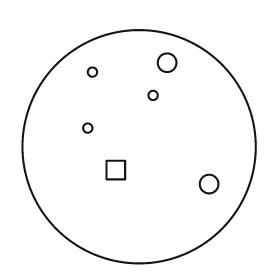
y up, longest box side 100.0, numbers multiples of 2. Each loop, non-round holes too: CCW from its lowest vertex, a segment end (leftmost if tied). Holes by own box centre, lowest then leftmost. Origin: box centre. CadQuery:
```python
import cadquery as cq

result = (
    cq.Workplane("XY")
    .moveTo(0.0, 0.0)
    .circle(50.0)
    .moveTo(30.0, -16.0)
    .circle(4.0)
    .moveTo(-14.0, -14.0)
    .lineTo(-6.0, -14.0)
    .lineTo(-6.0, -6.0)
    .lineTo(-14.0, -6.0)
    .close()
    .moveTo(-22.0, 8.0)
    .circle(2.0)
    .moveTo(6.0, 22.0)
    .circle(2.0)
    .moveTo(-20.0, 32.0)
    .circle(2.0)
    .moveTo(12.0, 36.0)
    .circle(4.0)
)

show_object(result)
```